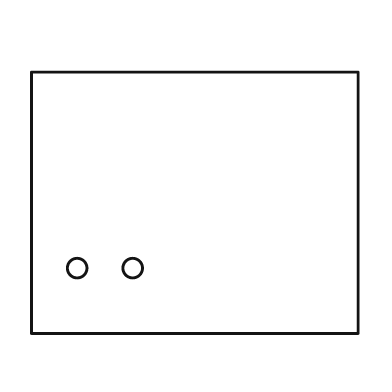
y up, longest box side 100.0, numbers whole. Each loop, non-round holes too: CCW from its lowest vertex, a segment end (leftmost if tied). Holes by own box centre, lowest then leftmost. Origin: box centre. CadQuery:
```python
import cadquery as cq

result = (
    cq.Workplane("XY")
    .moveTo(-50.0, -40.0)
    .lineTo(50.0, -40.0)
    .lineTo(50.0, 40.0)
    .lineTo(-50.0, 40.0)
    .close()
    .moveTo(-36.0, -20.0)
    .circle(3.0)
    .moveTo(-19.0, -20.0)
    .circle(3.0)
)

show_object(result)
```